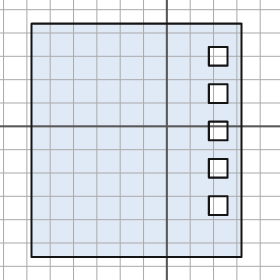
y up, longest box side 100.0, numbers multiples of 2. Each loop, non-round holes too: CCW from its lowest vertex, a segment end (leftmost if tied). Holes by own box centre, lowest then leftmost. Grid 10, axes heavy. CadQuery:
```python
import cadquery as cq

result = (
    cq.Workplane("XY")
    .moveTo(-58.0, -56.0)
    .lineTo(32.0, -56.0)
    .lineTo(32.0, 44.0)
    .lineTo(-58.0, 44.0)
    .close()
    .moveTo(18.0, -38.0)
    .lineTo(26.0, -38.0)
    .lineTo(26.0, -30.0)
    .lineTo(18.0, -30.0)
    .close()
    .moveTo(18.0, -22.0)
    .lineTo(26.0, -22.0)
    .lineTo(26.0, -14.0)
    .lineTo(18.0, -14.0)
    .close()
    .moveTo(18.0, -6.0)
    .lineTo(26.0, -6.0)
    .lineTo(26.0, 2.0)
    .lineTo(18.0, 2.0)
    .close()
    .moveTo(18.0, 10.0)
    .lineTo(26.0, 10.0)
    .lineTo(26.0, 18.0)
    .lineTo(18.0, 18.0)
    .close()
    .moveTo(18.0, 26.0)
    .lineTo(26.0, 26.0)
    .lineTo(26.0, 34.0)
    .lineTo(18.0, 34.0)
    .close()
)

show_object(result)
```